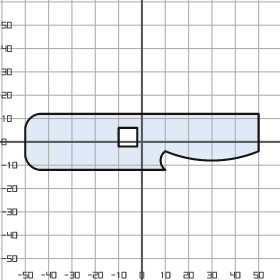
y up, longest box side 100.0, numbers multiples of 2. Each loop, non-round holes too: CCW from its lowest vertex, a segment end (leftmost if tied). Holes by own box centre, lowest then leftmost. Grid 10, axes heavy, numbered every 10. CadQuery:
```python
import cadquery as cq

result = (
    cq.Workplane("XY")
    .moveTo(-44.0, -12.0)
    .lineTo(10.0, -12.0)
    .threePointArc((8.0, -8.0), (10.0, -4.0))
    .threePointArc((30.0, -8.0), (50.0, -4.0))
    .lineTo(50.0, 12.0)
    .lineTo(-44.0, 12.0)
    .threePointArc((-48.0, 10.0), (-50.0, 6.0))
    .lineTo(-50.0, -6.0)
    .threePointArc((-48.0, -10.0), (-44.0, -12.0))
    .close()
    .moveTo(-10.0, -2.0)
    .lineTo(-2.0, -2.0)
    .lineTo(-2.0, 6.0)
    .lineTo(-10.0, 6.0)
    .close()
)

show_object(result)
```